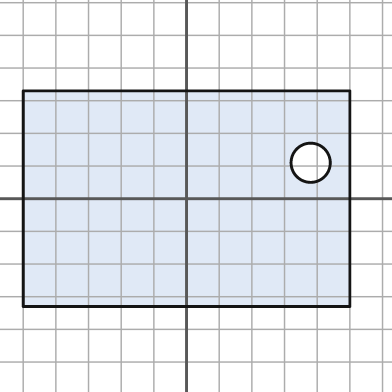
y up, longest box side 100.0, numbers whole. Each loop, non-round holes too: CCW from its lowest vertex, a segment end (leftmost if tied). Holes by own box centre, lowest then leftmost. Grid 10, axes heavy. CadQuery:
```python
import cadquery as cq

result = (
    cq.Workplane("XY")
    .moveTo(-50.0, -33.0)
    .lineTo(50.0, -33.0)
    .lineTo(50.0, 33.0)
    .lineTo(-50.0, 33.0)
    .close()
    .moveTo(38.0, 11.0)
    .circle(6.0)
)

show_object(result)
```